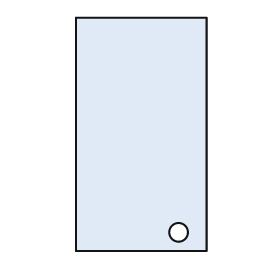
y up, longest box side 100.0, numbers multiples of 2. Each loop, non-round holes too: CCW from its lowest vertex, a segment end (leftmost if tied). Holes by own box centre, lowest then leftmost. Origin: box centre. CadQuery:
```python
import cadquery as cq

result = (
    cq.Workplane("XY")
    .moveTo(-28.0, -50.0)
    .lineTo(28.0, -50.0)
    .lineTo(28.0, 50.0)
    .lineTo(-28.0, 50.0)
    .close()
    .moveTo(16.0, -42.0)
    .circle(4.0)
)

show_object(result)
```